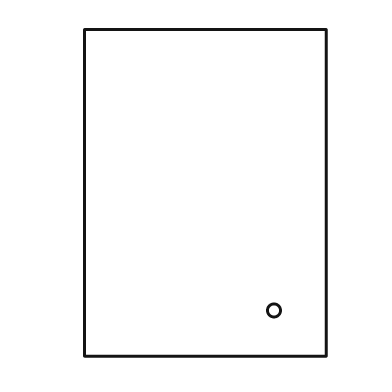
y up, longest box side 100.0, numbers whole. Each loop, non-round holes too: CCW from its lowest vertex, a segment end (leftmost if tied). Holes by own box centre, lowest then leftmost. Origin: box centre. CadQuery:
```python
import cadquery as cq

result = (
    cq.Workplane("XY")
    .moveTo(-37.0, -50.0)
    .lineTo(37.0, -50.0)
    .lineTo(37.0, 50.0)
    .lineTo(-37.0, 50.0)
    .close()
    .moveTo(21.0, -36.0)
    .circle(2.0)
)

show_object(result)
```